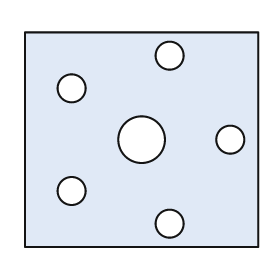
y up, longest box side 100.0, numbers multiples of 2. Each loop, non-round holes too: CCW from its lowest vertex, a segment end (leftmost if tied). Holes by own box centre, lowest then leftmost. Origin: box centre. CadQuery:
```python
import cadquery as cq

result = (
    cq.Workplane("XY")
    .moveTo(-50.0, -46.0)
    .lineTo(50.0, -46.0)
    .lineTo(50.0, 46.0)
    .lineTo(-50.0, 46.0)
    .close()
    .moveTo(12.0, -36.0)
    .circle(6.0)
    .moveTo(-30.0, -22.0)
    .circle(6.0)
    .moveTo(0.0, 0.0)
    .circle(10.0)
    .moveTo(38.0, 0.0)
    .circle(6.0)
    .moveTo(-30.0, 22.0)
    .circle(6.0)
    .moveTo(12.0, 36.0)
    .circle(6.0)
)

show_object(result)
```